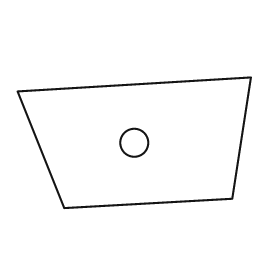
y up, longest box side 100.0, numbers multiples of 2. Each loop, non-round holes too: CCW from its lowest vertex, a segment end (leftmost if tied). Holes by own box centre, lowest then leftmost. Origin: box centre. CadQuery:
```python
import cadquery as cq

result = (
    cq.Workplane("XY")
    .moveTo(-30.0, -28.0)
    .lineTo(42.0, -24.0)
    .lineTo(50.0, 28.0)
    .lineTo(-50.0, 22.0)
    .close()
    .moveTo(0.0, 0.0)
    .circle(6.0)
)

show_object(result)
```